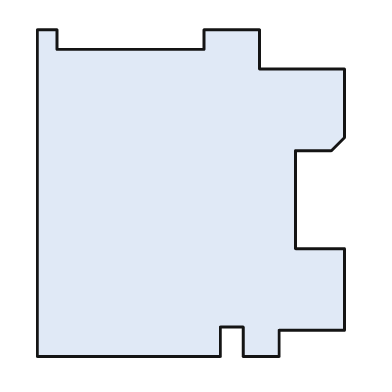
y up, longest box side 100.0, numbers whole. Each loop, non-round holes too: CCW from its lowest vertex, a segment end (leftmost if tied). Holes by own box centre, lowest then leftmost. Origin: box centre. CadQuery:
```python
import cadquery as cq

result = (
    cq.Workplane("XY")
    .moveTo(-47.0, -50.0)
    .lineTo(9.0, -50.0)
    .lineTo(9.0, -41.0)
    .lineTo(16.0, -41.0)
    .lineTo(16.0, -50.0)
    .lineTo(27.0, -50.0)
    .lineTo(27.0, -42.0)
    .lineTo(47.0, -42.0)
    .lineTo(47.0, -17.0)
    .lineTo(32.0, -17.0)
    .lineTo(32.0, 13.0)
    .lineTo(43.0, 13.0)
    .lineTo(47.0, 17.0)
    .lineTo(47.0, 38.0)
    .lineTo(21.0, 38.0)
    .lineTo(21.0, 50.0)
    .lineTo(4.0, 50.0)
    .lineTo(4.0, 44.0)
    .lineTo(-41.0, 44.0)
    .lineTo(-41.0, 50.0)
    .lineTo(-47.0, 50.0)
    .close()
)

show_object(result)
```